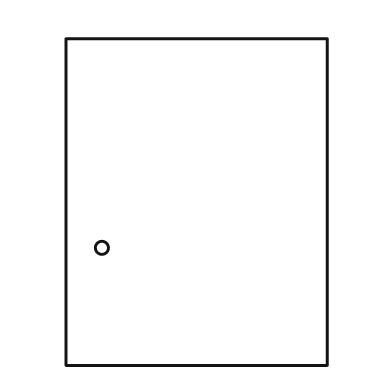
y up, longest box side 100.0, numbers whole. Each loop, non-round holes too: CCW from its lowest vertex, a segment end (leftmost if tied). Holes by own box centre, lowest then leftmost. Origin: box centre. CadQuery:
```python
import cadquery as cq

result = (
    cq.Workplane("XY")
    .moveTo(-40.0, -50.0)
    .lineTo(40.0, -50.0)
    .lineTo(40.0, 50.0)
    .lineTo(-40.0, 50.0)
    .close()
    .moveTo(-29.0, -14.0)
    .circle(2.0)
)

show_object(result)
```